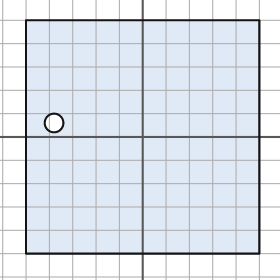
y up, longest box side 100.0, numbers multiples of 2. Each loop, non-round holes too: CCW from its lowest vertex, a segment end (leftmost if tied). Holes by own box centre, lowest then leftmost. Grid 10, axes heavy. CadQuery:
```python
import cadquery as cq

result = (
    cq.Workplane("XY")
    .moveTo(-50.0, -50.0)
    .lineTo(50.0, -50.0)
    .lineTo(50.0, 50.0)
    .lineTo(-50.0, 50.0)
    .close()
    .moveTo(-38.0, 6.0)
    .circle(4.0)
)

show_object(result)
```